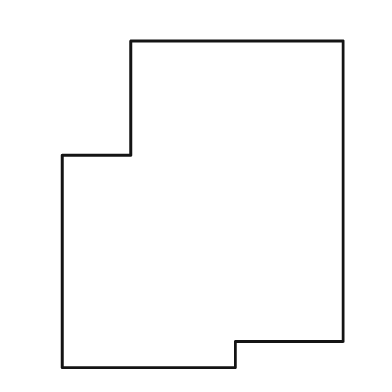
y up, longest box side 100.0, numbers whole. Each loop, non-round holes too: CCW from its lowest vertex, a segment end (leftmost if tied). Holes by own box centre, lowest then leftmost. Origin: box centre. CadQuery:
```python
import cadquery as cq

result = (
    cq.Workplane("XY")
    .moveTo(-43.0, -50.0)
    .lineTo(10.0, -50.0)
    .lineTo(10.0, -42.0)
    .lineTo(43.0, -42.0)
    .lineTo(43.0, 50.0)
    .lineTo(-22.0, 50.0)
    .lineTo(-22.0, 15.0)
    .lineTo(-43.0, 15.0)
    .close()
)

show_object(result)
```